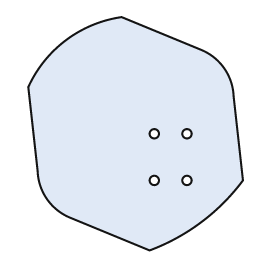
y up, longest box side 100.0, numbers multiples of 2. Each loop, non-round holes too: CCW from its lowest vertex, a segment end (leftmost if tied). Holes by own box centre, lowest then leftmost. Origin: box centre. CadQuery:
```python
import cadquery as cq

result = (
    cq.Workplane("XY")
    .moveTo(6.0, -50.0)
    .threePointArc((28.0, -38.0), (46.0, -20.0))
    .lineTo(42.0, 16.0)
    .threePointArc((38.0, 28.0), (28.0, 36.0))
    .lineTo(-6.0, 50.0)
    .threePointArc((-30.0, 40.0), (-46.0, 20.0))
    .lineTo(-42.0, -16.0)
    .threePointArc((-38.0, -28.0), (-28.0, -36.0))
    .close()
    .moveTo(8.0, -20.0)
    .circle(2.0)
    .moveTo(22.0, -20.0)
    .circle(2.0)
    .moveTo(8.0, 0.0)
    .circle(2.0)
    .moveTo(22.0, 0.0)
    .circle(2.0)
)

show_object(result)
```